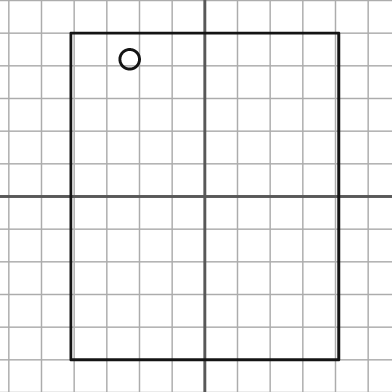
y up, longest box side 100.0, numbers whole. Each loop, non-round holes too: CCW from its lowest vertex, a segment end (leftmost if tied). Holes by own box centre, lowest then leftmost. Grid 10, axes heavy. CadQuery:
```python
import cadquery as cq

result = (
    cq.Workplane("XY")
    .moveTo(-41.0, -50.0)
    .lineTo(41.0, -50.0)
    .lineTo(41.0, 50.0)
    .lineTo(-41.0, 50.0)
    .close()
    .moveTo(-23.0, 42.0)
    .circle(3.0)
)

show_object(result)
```